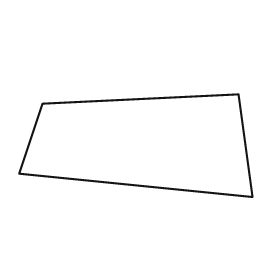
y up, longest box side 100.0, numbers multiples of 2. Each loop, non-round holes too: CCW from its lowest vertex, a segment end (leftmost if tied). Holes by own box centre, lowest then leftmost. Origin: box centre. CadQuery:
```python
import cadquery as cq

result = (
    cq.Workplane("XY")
    .moveTo(50.0, -22.0)
    .lineTo(44.0, 22.0)
    .lineTo(-40.0, 18.0)
    .lineTo(-50.0, -12.0)
    .close()
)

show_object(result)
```